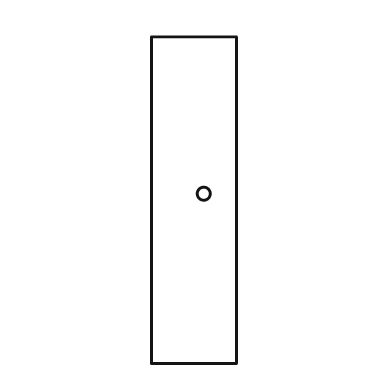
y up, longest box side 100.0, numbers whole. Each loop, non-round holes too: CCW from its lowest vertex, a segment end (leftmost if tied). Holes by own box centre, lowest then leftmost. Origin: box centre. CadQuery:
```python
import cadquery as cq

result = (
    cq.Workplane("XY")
    .moveTo(-13.0, -50.0)
    .lineTo(13.0, -50.0)
    .lineTo(13.0, 50.0)
    .lineTo(-13.0, 50.0)
    .close()
    .moveTo(3.0, 2.0)
    .circle(2.0)
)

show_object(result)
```